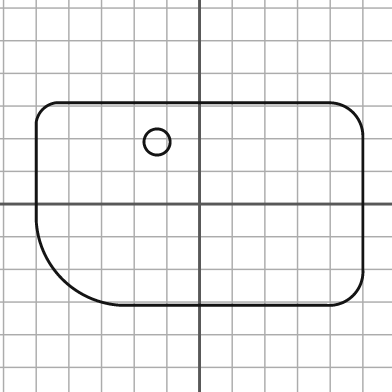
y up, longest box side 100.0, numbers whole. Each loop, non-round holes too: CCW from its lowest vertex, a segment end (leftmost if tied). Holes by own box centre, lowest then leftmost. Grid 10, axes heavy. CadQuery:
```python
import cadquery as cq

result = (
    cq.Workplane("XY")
    .moveTo(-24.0, -31.0)
    .lineTo(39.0, -31.0)
    .threePointArc((47.0, -28.0), (50.0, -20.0))
    .lineTo(50.0, 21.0)
    .threePointArc((47.0, 28.0), (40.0, 31.0))
    .lineTo(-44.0, 31.0)
    .threePointArc((-48.0, 29.0), (-50.0, 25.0))
    .lineTo(-50.0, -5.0)
    .threePointArc((-42.0, -23.0), (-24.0, -31.0))
    .close()
    .moveTo(-13.0, 19.0)
    .circle(4.0)
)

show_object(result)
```